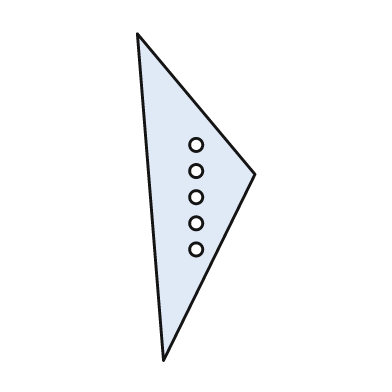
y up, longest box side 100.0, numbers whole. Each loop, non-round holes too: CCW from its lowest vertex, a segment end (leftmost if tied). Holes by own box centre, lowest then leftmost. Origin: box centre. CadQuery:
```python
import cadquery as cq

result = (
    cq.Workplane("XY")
    .moveTo(-10.0, -50.0)
    .lineTo(18.0, 7.0)
    .lineTo(-18.0, 50.0)
    .close()
    .moveTo(0.0, -16.0)
    .circle(2.0)
    .moveTo(0.0, -8.0)
    .circle(2.0)
    .moveTo(0.0, 0.0)
    .circle(2.0)
    .moveTo(0.0, 8.0)
    .circle(2.0)
    .moveTo(0.0, 16.0)
    .circle(2.0)
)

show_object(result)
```